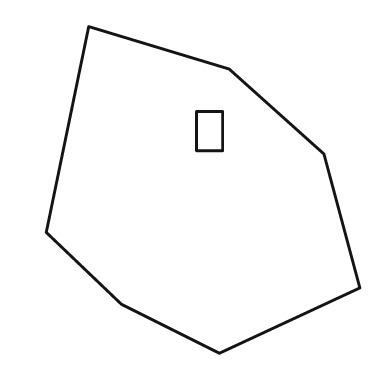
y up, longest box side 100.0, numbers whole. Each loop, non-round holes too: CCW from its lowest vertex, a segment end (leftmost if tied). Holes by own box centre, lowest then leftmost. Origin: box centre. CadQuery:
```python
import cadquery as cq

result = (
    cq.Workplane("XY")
    .moveTo(5.0, -50.0)
    .lineTo(48.0, -30.0)
    .lineTo(37.0, 11.0)
    .lineTo(8.0, 37.0)
    .lineTo(-35.0, 50.0)
    .lineTo(-48.0, -13.0)
    .lineTo(-25.0, -35.0)
    .close()
    .moveTo(-2.0, 12.0)
    .lineTo(6.0, 12.0)
    .lineTo(6.0, 24.0)
    .lineTo(-2.0, 24.0)
    .close()
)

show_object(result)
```